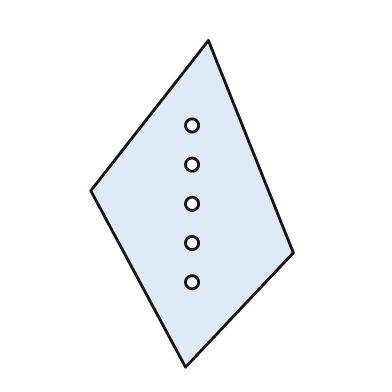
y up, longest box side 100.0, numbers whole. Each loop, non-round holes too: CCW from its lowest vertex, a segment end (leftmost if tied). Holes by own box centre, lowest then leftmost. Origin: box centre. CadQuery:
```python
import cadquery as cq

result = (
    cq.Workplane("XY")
    .moveTo(-2.0, -50.0)
    .lineTo(31.0, -15.0)
    .lineTo(5.0, 50.0)
    .lineTo(-31.0, 4.0)
    .close()
    .moveTo(0.0, -24.0)
    .circle(2.0)
    .moveTo(0.0, -12.0)
    .circle(2.0)
    .moveTo(0.0, 0.0)
    .circle(2.0)
    .moveTo(0.0, 12.0)
    .circle(2.0)
    .moveTo(0.0, 24.0)
    .circle(2.0)
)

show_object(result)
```